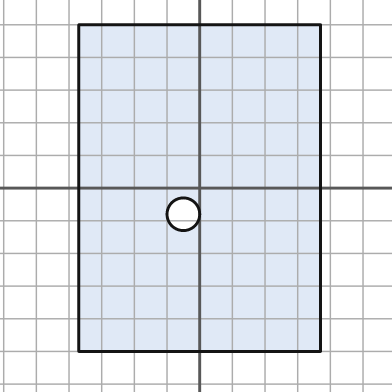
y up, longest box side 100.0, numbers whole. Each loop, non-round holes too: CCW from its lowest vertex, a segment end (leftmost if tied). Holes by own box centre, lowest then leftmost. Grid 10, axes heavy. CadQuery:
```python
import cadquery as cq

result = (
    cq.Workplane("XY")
    .moveTo(-37.0, -50.0)
    .lineTo(37.0, -50.0)
    .lineTo(37.0, 50.0)
    .lineTo(-37.0, 50.0)
    .close()
    .moveTo(-5.0, -8.0)
    .circle(5.0)
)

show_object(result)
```